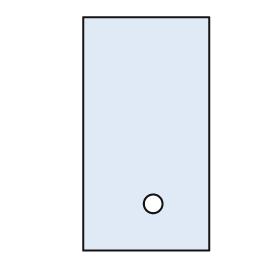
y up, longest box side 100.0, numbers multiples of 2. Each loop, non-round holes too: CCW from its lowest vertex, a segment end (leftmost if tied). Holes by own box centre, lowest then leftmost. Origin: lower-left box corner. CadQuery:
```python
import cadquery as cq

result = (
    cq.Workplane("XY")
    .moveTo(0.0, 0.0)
    .lineTo(54.0, 0.0)
    .lineTo(54.0, 100.0)
    .lineTo(0.0, 100.0)
    .close()
    .moveTo(30.0, 20.0)
    .circle(4.0)
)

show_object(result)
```